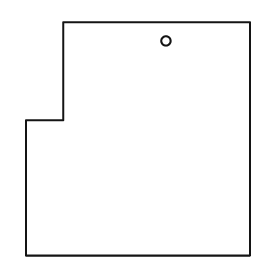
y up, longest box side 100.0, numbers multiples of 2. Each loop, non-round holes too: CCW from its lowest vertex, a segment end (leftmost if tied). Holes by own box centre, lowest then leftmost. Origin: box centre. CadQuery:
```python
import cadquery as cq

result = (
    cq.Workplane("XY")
    .moveTo(-48.0, -50.0)
    .lineTo(48.0, -50.0)
    .lineTo(48.0, 50.0)
    .lineTo(-32.0, 50.0)
    .lineTo(-32.0, 8.0)
    .lineTo(-48.0, 8.0)
    .close()
    .moveTo(12.0, 42.0)
    .circle(2.0)
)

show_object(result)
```